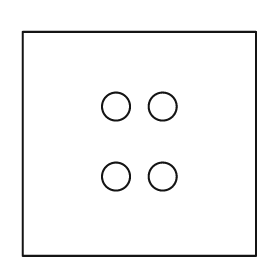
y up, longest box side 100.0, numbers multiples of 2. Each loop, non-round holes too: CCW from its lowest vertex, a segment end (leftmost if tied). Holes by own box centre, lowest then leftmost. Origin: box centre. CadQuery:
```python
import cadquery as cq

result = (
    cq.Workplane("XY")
    .moveTo(-50.0, -48.0)
    .lineTo(50.0, -48.0)
    .lineTo(50.0, 48.0)
    .lineTo(-50.0, 48.0)
    .close()
    .moveTo(-10.0, -14.0)
    .circle(6.0)
    .moveTo(10.0, -14.0)
    .circle(6.0)
    .moveTo(-10.0, 16.0)
    .circle(6.0)
    .moveTo(10.0, 16.0)
    .circle(6.0)
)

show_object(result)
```